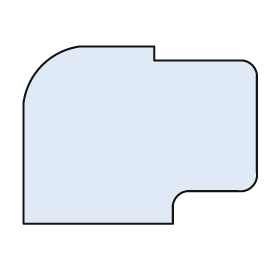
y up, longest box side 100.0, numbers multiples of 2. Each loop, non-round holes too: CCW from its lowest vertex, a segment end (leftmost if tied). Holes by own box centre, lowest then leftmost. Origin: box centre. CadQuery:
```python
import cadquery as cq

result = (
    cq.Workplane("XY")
    .moveTo(-50.0, -38.0)
    .lineTo(14.0, -38.0)
    .lineTo(14.0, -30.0)
    .threePointArc((16.0, -26.0), (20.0, -24.0))
    .lineTo(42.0, -24.0)
    .threePointArc((48.0, -22.0), (50.0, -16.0))
    .lineTo(50.0, 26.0)
    .threePointArc((48.0, 30.0), (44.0, 32.0))
    .lineTo(6.0, 32.0)
    .lineTo(6.0, 38.0)
    .lineTo(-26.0, 38.0)
    .threePointArc((-42.0, 30.0), (-50.0, 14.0))
    .close()
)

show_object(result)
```